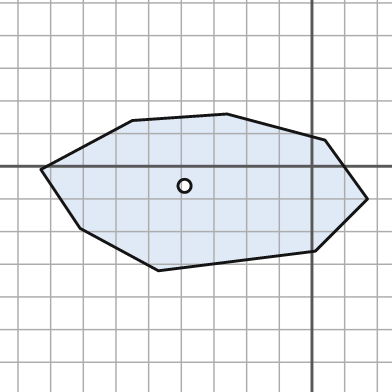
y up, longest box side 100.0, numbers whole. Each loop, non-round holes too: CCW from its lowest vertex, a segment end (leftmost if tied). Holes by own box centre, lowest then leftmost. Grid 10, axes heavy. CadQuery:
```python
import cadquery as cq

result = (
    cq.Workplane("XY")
    .moveTo(-47.0, -32.0)
    .lineTo(1.0, -26.0)
    .lineTo(17.0, -10.0)
    .lineTo(4.0, 8.0)
    .lineTo(-26.0, 16.0)
    .lineTo(-55.0, 14.0)
    .lineTo(-83.0, -1.0)
    .lineTo(-71.0, -19.0)
    .close()
    .moveTo(-39.0, -6.0)
    .circle(2.0)
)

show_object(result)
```